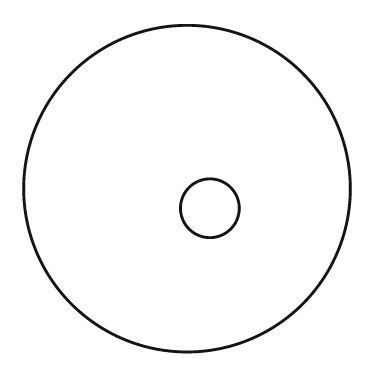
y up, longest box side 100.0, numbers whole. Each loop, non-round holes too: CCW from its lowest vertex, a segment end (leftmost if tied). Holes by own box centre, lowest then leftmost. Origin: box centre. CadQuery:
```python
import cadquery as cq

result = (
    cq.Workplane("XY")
    .moveTo(0.0, 0.0)
    .circle(50.0)
    .moveTo(7.0, -6.0)
    .circle(9.0)
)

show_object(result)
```